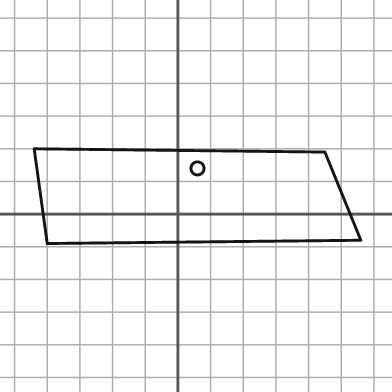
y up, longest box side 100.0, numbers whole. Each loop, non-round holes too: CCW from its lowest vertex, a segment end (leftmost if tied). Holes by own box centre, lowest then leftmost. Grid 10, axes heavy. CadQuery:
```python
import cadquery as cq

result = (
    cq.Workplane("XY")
    .moveTo(-40.0, -9.0)
    .lineTo(56.0, -8.0)
    .lineTo(45.0, 19.0)
    .lineTo(-44.0, 20.0)
    .close()
    .moveTo(6.0, 14.0)
    .circle(2.0)
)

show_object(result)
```